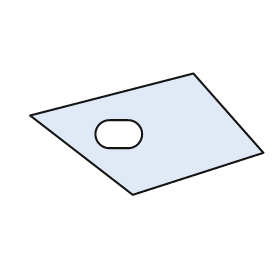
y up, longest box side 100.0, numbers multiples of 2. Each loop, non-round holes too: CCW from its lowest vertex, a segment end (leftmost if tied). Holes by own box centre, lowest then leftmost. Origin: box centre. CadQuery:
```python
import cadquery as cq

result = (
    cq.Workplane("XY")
    .moveTo(-6.0, -26.0)
    .lineTo(50.0, -8.0)
    .lineTo(20.0, 26.0)
    .lineTo(-50.0, 8.0)
    .close()
    .moveTo(-16.0, -6.0)
    .lineTo(-8.0, -6.0)
    .threePointArc((-2.0, 0.0), (-8.0, 6.0))
    .lineTo(-16.0, 6.0)
    .threePointArc((-22.0, 0.0), (-16.0, -6.0))
    .close()
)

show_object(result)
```